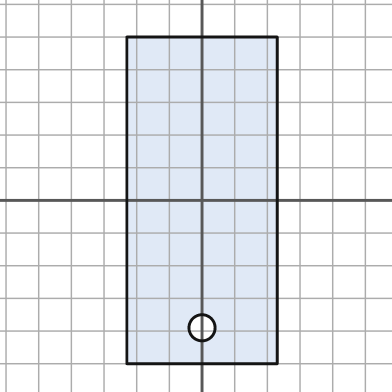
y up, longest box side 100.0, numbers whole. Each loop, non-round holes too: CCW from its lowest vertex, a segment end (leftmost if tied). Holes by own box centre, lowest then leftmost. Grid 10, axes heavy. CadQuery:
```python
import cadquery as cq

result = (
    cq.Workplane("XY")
    .moveTo(-23.0, -50.0)
    .lineTo(23.0, -50.0)
    .lineTo(23.0, 50.0)
    .lineTo(-23.0, 50.0)
    .close()
    .moveTo(0.0, -39.0)
    .circle(4.0)
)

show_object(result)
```